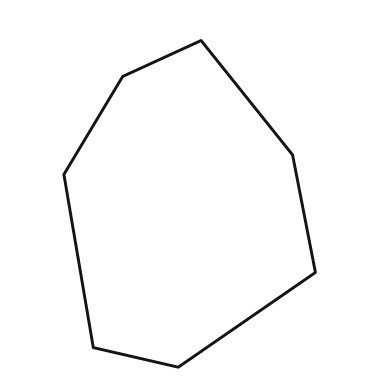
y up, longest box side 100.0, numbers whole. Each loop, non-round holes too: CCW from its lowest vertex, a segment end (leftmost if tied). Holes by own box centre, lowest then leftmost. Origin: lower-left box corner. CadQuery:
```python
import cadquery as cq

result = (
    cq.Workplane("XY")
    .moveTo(35.0, 0.0)
    .lineTo(77.0, 29.0)
    .lineTo(70.0, 65.0)
    .lineTo(42.0, 100.0)
    .lineTo(18.0, 89.0)
    .lineTo(0.0, 59.0)
    .lineTo(9.0, 6.0)
    .close()
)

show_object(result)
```